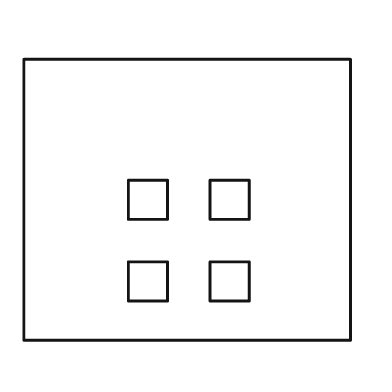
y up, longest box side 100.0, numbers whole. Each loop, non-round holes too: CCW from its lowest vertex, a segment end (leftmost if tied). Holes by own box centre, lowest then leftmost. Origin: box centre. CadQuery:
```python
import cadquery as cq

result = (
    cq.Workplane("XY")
    .moveTo(-50.0, -43.0)
    .lineTo(50.0, -43.0)
    .lineTo(50.0, 43.0)
    .lineTo(-50.0, 43.0)
    .close()
    .moveTo(-18.0, -31.0)
    .lineTo(-6.0, -31.0)
    .lineTo(-6.0, -19.0)
    .lineTo(-18.0, -19.0)
    .close()
    .moveTo(7.0, -31.0)
    .lineTo(19.0, -31.0)
    .lineTo(19.0, -19.0)
    .lineTo(7.0, -19.0)
    .close()
    .moveTo(-18.0, -6.0)
    .lineTo(-6.0, -6.0)
    .lineTo(-6.0, 6.0)
    .lineTo(-18.0, 6.0)
    .close()
    .moveTo(7.0, -6.0)
    .lineTo(19.0, -6.0)
    .lineTo(19.0, 6.0)
    .lineTo(7.0, 6.0)
    .close()
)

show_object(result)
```